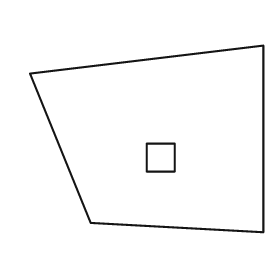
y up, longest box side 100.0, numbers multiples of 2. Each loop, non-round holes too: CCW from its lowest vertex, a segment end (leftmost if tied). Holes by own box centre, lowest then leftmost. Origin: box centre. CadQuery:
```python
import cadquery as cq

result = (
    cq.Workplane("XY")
    .moveTo(50.0, -40.0)
    .lineTo(50.0, 40.0)
    .lineTo(-50.0, 28.0)
    .lineTo(-24.0, -36.0)
    .close()
    .moveTo(0.0, -14.0)
    .lineTo(12.0, -14.0)
    .lineTo(12.0, -2.0)
    .lineTo(0.0, -2.0)
    .close()
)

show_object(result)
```